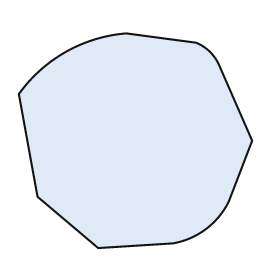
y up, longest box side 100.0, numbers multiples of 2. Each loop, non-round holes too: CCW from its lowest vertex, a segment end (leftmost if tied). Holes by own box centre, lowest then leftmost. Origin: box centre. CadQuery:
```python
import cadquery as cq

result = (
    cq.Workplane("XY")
    .moveTo(-16.0, -46.0)
    .lineTo(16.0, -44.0)
    .threePointArc((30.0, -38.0), (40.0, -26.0))
    .lineTo(50.0, 0.0)
    .lineTo(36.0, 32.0)
    .threePointArc((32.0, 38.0), (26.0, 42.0))
    .lineTo(-4.0, 46.0)
    .threePointArc((-30.0, 38.0), (-50.0, 20.0))
    .lineTo(-42.0, -24.0)
    .close()
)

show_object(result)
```